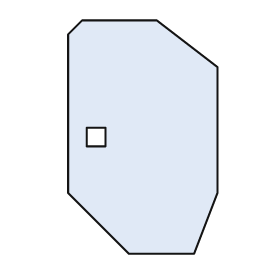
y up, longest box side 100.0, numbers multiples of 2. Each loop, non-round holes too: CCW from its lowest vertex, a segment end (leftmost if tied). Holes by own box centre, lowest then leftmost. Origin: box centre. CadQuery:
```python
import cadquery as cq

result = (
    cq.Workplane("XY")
    .moveTo(-6.0, -50.0)
    .lineTo(22.0, -50.0)
    .lineTo(32.0, -24.0)
    .lineTo(32.0, 30.0)
    .lineTo(6.0, 50.0)
    .lineTo(-26.0, 50.0)
    .lineTo(-32.0, 44.0)
    .lineTo(-32.0, -24.0)
    .close()
    .moveTo(-24.0, -4.0)
    .lineTo(-16.0, -4.0)
    .lineTo(-16.0, 4.0)
    .lineTo(-24.0, 4.0)
    .close()
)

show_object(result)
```